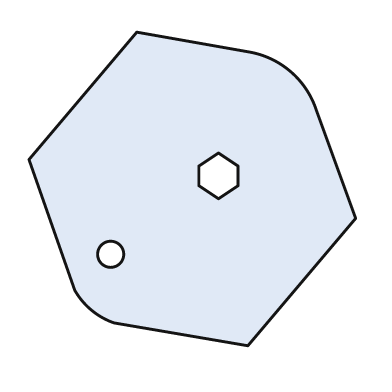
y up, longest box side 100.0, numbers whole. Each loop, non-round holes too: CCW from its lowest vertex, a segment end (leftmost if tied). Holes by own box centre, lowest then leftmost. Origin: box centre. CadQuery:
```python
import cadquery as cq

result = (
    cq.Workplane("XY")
    .moveTo(17.0, -48.0)
    .lineTo(50.0, -9.0)
    .lineTo(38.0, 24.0)
    .threePointArc((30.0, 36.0), (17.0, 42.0))
    .lineTo(-17.0, 48.0)
    .lineTo(-50.0, 9.0)
    .lineTo(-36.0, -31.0)
    .threePointArc((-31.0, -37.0), (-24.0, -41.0))
    .close()
    .moveTo(-25.0, -20.0)
    .circle(4.0)
    .moveTo(8.0, -3.0)
    .lineTo(14.0, 1.0)
    .lineTo(14.0, 7.0)
    .lineTo(8.0, 11.0)
    .lineTo(2.0, 7.0)
    .lineTo(2.0, 1.0)
    .close()
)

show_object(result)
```